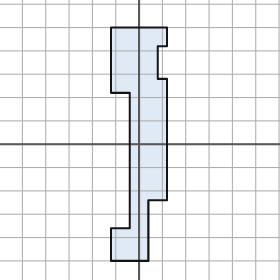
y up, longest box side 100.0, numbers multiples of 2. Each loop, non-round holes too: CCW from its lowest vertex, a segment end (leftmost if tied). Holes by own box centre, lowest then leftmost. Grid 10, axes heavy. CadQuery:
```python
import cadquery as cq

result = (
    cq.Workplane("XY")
    .moveTo(-12.0, -50.0)
    .lineTo(4.0, -50.0)
    .lineTo(4.0, -24.0)
    .lineTo(12.0, -24.0)
    .lineTo(12.0, 28.0)
    .lineTo(8.0, 28.0)
    .lineTo(8.0, 42.0)
    .lineTo(12.0, 42.0)
    .lineTo(12.0, 50.0)
    .lineTo(-12.0, 50.0)
    .lineTo(-12.0, 22.0)
    .lineTo(-4.0, 22.0)
    .lineTo(-4.0, -36.0)
    .lineTo(-12.0, -36.0)
    .close()
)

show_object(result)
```